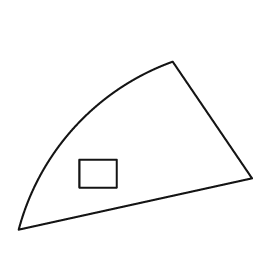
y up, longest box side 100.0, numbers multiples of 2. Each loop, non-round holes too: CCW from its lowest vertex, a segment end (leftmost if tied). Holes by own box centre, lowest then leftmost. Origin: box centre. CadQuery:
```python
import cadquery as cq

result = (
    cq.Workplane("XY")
    .moveTo(-50.0, -36.0)
    .lineTo(50.0, -14.0)
    .lineTo(16.0, 36.0)
    .threePointArc((-26.0, 8.0), (-50.0, -36.0))
    .close()
    .moveTo(-24.0, -18.0)
    .lineTo(-8.0, -18.0)
    .lineTo(-8.0, -6.0)
    .lineTo(-24.0, -6.0)
    .close()
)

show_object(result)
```